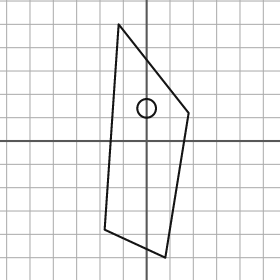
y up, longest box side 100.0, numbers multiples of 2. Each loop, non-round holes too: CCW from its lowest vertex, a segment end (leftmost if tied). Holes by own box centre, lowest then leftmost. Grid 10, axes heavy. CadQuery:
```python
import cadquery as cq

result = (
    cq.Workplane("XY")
    .moveTo(8.0, -50.0)
    .lineTo(18.0, 12.0)
    .lineTo(-12.0, 50.0)
    .lineTo(-18.0, -38.0)
    .close()
    .moveTo(0.0, 14.0)
    .circle(4.0)
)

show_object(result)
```